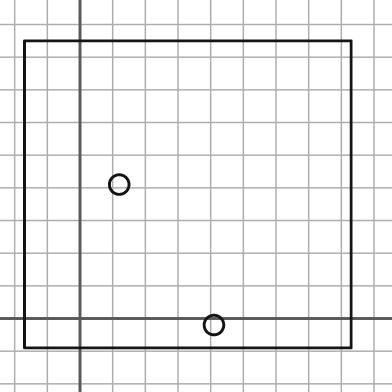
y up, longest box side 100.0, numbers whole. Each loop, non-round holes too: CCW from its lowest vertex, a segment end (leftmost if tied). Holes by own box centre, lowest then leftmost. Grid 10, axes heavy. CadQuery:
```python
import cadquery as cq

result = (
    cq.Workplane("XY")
    .moveTo(-17.0, -9.0)
    .lineTo(83.0, -9.0)
    .lineTo(83.0, 85.0)
    .lineTo(-17.0, 85.0)
    .close()
    .moveTo(41.0, -2.0)
    .circle(3.0)
    .moveTo(12.0, 41.0)
    .circle(3.0)
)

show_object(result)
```